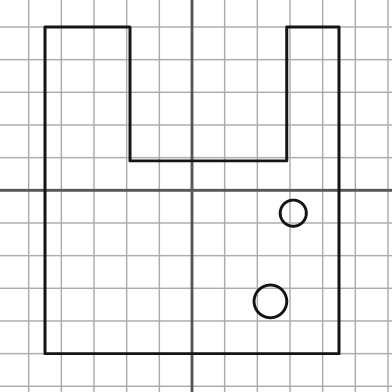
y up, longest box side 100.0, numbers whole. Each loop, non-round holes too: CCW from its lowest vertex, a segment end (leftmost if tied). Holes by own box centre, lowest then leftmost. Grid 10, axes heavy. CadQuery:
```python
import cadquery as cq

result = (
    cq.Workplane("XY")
    .moveTo(-45.0, -50.0)
    .lineTo(45.0, -50.0)
    .lineTo(45.0, 50.0)
    .lineTo(29.0, 50.0)
    .lineTo(29.0, 9.0)
    .lineTo(-19.0, 9.0)
    .lineTo(-19.0, 50.0)
    .lineTo(-45.0, 50.0)
    .close()
    .moveTo(24.0, -34.0)
    .circle(5.0)
    .moveTo(31.0, -7.0)
    .circle(4.0)
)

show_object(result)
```